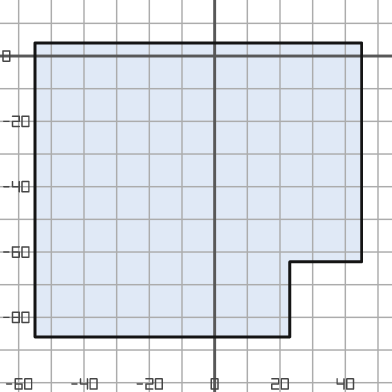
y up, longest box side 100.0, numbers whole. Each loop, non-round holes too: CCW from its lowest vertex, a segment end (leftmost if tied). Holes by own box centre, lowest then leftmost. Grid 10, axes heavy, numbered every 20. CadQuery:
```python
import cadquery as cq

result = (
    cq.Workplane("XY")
    .moveTo(-55.0, -86.0)
    .lineTo(23.0, -86.0)
    .lineTo(23.0, -63.0)
    .lineTo(45.0, -63.0)
    .lineTo(45.0, 4.0)
    .lineTo(-55.0, 4.0)
    .close()
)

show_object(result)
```